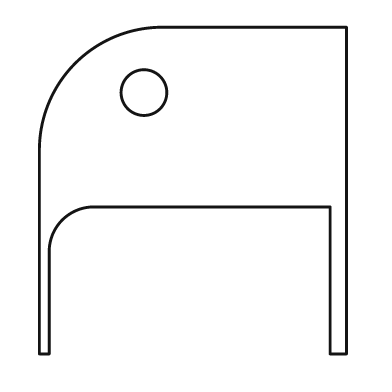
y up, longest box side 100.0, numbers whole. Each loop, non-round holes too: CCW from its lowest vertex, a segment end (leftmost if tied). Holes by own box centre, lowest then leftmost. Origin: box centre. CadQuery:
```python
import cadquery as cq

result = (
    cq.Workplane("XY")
    .moveTo(-47.0, -50.0)
    .lineTo(-44.0, -50.0)
    .lineTo(-44.0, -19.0)
    .threePointArc((-40.0, -9.0), (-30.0, -5.0))
    .lineTo(42.0, -5.0)
    .lineTo(42.0, -50.0)
    .lineTo(47.0, -50.0)
    .lineTo(47.0, 50.0)
    .lineTo(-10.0, 50.0)
    .threePointArc((-36.0, 39.0), (-47.0, 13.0))
    .close()
    .moveTo(-15.0, 30.0)
    .circle(7.0)
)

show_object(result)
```